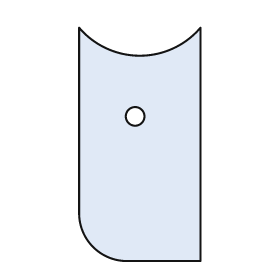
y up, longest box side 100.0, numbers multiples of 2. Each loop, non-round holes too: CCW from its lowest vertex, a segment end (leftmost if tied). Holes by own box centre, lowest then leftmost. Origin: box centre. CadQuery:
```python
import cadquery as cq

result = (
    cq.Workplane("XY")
    .moveTo(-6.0, -50.0)
    .lineTo(26.0, -50.0)
    .lineTo(26.0, 50.0)
    .threePointArc((0.0, 38.0), (-26.0, 50.0))
    .lineTo(-26.0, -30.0)
    .threePointArc((-20.0, -44.0), (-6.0, -50.0))
    .close()
    .moveTo(-2.0, 12.0)
    .circle(4.0)
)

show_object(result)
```